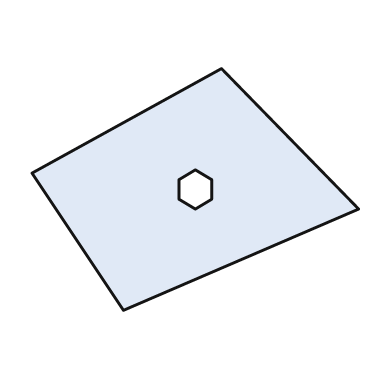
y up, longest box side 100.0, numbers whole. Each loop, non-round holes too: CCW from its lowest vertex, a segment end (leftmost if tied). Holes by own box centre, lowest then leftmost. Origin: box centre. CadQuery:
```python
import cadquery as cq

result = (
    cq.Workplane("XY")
    .moveTo(-22.0, -37.0)
    .lineTo(50.0, -6.0)
    .lineTo(8.0, 37.0)
    .lineTo(-50.0, 5.0)
    .close()
    .moveTo(0.0, -6.0)
    .lineTo(5.0, -3.0)
    .lineTo(5.0, 3.0)
    .lineTo(0.0, 6.0)
    .lineTo(-5.0, 3.0)
    .lineTo(-5.0, -3.0)
    .close()
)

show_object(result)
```